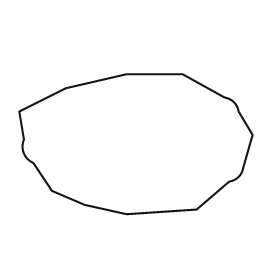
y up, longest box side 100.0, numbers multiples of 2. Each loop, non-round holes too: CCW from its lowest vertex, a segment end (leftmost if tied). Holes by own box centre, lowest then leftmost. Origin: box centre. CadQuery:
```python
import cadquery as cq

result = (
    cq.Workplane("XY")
    .moveTo(-4.0, -30.0)
    .lineTo(26.0, -28.0)
    .lineTo(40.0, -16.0)
    .threePointArc((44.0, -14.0), (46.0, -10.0))
    .lineTo(50.0, 4.0)
    .lineTo(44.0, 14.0)
    .threePointArc((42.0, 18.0), (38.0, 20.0))
    .lineTo(20.0, 30.0)
    .lineTo(-4.0, 30.0)
    .lineTo(-30.0, 24.0)
    .lineTo(-50.0, 14.0)
    .lineTo(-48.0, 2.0)
    .threePointArc((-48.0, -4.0), (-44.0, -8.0))
    .lineTo(-36.0, -20.0)
    .lineTo(-22.0, -26.0)
    .close()
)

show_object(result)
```